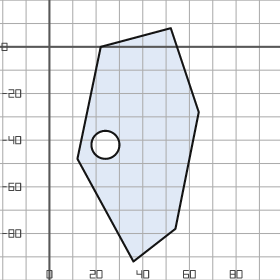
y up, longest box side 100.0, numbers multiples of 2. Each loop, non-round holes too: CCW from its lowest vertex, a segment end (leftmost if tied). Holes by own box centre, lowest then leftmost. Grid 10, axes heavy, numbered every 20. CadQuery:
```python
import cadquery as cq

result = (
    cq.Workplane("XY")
    .moveTo(36.0, -92.0)
    .lineTo(54.0, -78.0)
    .lineTo(64.0, -28.0)
    .lineTo(52.0, 8.0)
    .lineTo(22.0, 0.0)
    .lineTo(12.0, -48.0)
    .close()
    .moveTo(24.0, -42.0)
    .circle(6.0)
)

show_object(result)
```